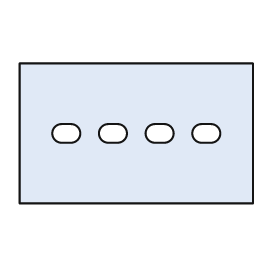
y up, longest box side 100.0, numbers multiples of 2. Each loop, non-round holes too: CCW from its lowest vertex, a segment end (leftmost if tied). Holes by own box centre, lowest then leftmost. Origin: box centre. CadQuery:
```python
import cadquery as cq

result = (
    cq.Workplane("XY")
    .moveTo(-50.0, -30.0)
    .lineTo(50.0, -30.0)
    .lineTo(50.0, 30.0)
    .lineTo(-50.0, 30.0)
    .close()
    .moveTo(-32.0, -4.0)
    .lineTo(-28.0, -4.0)
    .threePointArc((-24.0, 0.0), (-28.0, 4.0))
    .lineTo(-32.0, 4.0)
    .threePointArc((-36.0, 0.0), (-32.0, -4.0))
    .close()
    .moveTo(-12.0, -4.0)
    .lineTo(-8.0, -4.0)
    .threePointArc((-4.0, 0.0), (-8.0, 4.0))
    .lineTo(-12.0, 4.0)
    .threePointArc((-16.0, 0.0), (-12.0, -4.0))
    .close()
    .moveTo(8.0, -4.0)
    .lineTo(12.0, -4.0)
    .threePointArc((16.0, 0.0), (12.0, 4.0))
    .lineTo(8.0, 4.0)
    .threePointArc((4.0, 0.0), (8.0, -4.0))
    .close()
    .moveTo(28.0, -4.0)
    .lineTo(32.0, -4.0)
    .threePointArc((36.0, 0.0), (32.0, 4.0))
    .lineTo(28.0, 4.0)
    .threePointArc((24.0, 0.0), (28.0, -4.0))
    .close()
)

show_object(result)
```